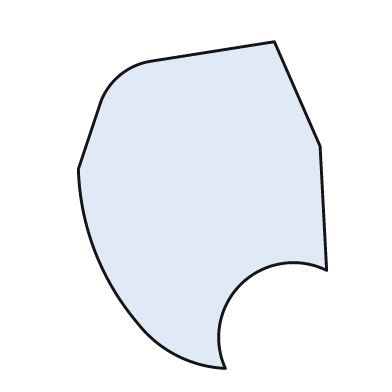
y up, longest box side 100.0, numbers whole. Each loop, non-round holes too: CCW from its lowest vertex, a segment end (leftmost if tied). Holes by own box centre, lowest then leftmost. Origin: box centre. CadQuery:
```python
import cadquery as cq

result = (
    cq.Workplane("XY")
    .moveTo(7.0, -50.0)
    .threePointArc((12.0, -24.0), (38.0, -20.0))
    .lineTo(36.0, 18.0)
    .lineTo(22.0, 50.0)
    .lineTo(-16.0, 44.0)
    .threePointArc((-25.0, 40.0), (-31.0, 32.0))
    .lineTo(-38.0, 11.0)
    .threePointArc((-33.0, -14.0), (-20.0, -36.0))
    .threePointArc((-8.0, -46.0), (7.0, -50.0))
    .close()
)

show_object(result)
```